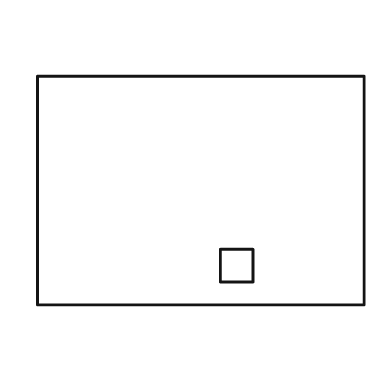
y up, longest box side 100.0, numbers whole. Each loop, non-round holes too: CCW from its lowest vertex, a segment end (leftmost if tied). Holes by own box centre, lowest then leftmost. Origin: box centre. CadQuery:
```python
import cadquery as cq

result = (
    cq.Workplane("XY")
    .moveTo(-50.0, -35.0)
    .lineTo(50.0, -35.0)
    .lineTo(50.0, 35.0)
    .lineTo(-50.0, 35.0)
    .close()
    .moveTo(6.0, -28.0)
    .lineTo(16.0, -28.0)
    .lineTo(16.0, -18.0)
    .lineTo(6.0, -18.0)
    .close()
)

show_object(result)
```